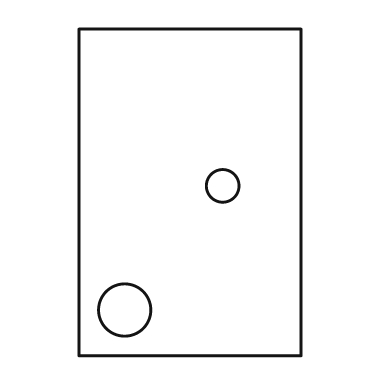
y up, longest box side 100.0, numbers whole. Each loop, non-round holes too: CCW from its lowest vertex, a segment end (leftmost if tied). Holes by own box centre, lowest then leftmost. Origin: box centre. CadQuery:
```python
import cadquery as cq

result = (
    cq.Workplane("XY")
    .moveTo(-34.0, -50.0)
    .lineTo(34.0, -50.0)
    .lineTo(34.0, 50.0)
    .lineTo(-34.0, 50.0)
    .close()
    .moveTo(-20.0, -36.0)
    .circle(8.0)
    .moveTo(10.0, 2.0)
    .circle(5.0)
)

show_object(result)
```